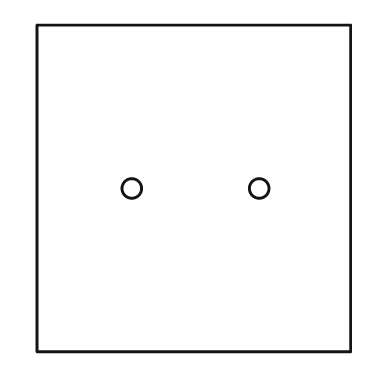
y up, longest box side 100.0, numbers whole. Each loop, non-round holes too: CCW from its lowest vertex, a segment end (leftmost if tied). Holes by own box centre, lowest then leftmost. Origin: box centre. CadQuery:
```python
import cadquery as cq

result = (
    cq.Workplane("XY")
    .moveTo(-48.0, -50.0)
    .lineTo(48.0, -50.0)
    .lineTo(48.0, 50.0)
    .lineTo(-48.0, 50.0)
    .close()
    .moveTo(-19.0, 0.0)
    .circle(3.0)
    .moveTo(20.0, 0.0)
    .circle(3.0)
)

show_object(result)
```